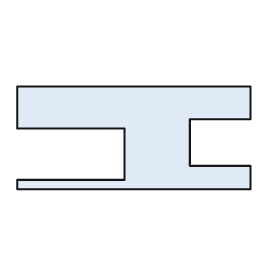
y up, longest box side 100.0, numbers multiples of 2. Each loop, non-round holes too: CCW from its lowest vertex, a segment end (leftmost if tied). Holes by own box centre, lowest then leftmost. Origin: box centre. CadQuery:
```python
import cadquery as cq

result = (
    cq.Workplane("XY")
    .moveTo(-50.0, -22.0)
    .lineTo(50.0, -22.0)
    .lineTo(50.0, -12.0)
    .lineTo(24.0, -12.0)
    .lineTo(24.0, 8.0)
    .lineTo(50.0, 8.0)
    .lineTo(50.0, 22.0)
    .lineTo(-50.0, 22.0)
    .lineTo(-50.0, 4.0)
    .lineTo(-4.0, 4.0)
    .lineTo(-4.0, -18.0)
    .lineTo(-50.0, -18.0)
    .close()
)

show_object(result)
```